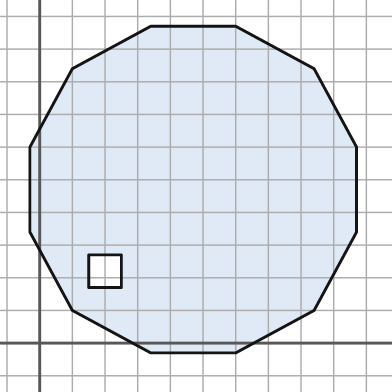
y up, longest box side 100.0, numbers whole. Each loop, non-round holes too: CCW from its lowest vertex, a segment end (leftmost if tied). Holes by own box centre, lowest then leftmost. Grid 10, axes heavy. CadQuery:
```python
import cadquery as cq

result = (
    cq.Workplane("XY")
    .moveTo(34.0, -3.0)
    .lineTo(60.0, -3.0)
    .lineTo(84.0, 10.0)
    .lineTo(97.0, 34.0)
    .lineTo(97.0, 60.0)
    .lineTo(84.0, 84.0)
    .lineTo(60.0, 97.0)
    .lineTo(34.0, 97.0)
    .lineTo(10.0, 84.0)
    .lineTo(-3.0, 60.0)
    .lineTo(-3.0, 34.0)
    .lineTo(10.0, 10.0)
    .close()
    .moveTo(15.0, 17.0)
    .lineTo(25.0, 17.0)
    .lineTo(25.0, 27.0)
    .lineTo(15.0, 27.0)
    .close()
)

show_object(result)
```